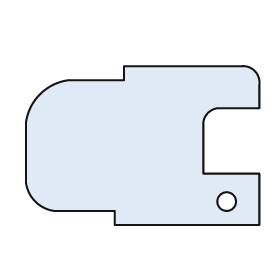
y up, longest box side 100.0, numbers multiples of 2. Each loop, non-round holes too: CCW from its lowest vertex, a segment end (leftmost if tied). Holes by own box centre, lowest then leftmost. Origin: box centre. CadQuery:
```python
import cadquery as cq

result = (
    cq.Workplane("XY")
    .moveTo(-12.0, -34.0)
    .lineTo(50.0, -34.0)
    .lineTo(50.0, -12.0)
    .lineTo(26.0, -12.0)
    .lineTo(26.0, 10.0)
    .threePointArc((28.0, 14.0), (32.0, 16.0))
    .lineTo(50.0, 16.0)
    .lineTo(50.0, 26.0)
    .threePointArc((48.0, 32.0), (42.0, 34.0))
    .lineTo(-8.0, 34.0)
    .lineTo(-8.0, 28.0)
    .lineTo(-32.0, 28.0)
    .threePointArc((-44.0, 22.0), (-50.0, 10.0))
    .lineTo(-50.0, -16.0)
    .threePointArc((-46.0, -24.0), (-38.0, -28.0))
    .lineTo(-12.0, -28.0)
    .close()
    .moveTo(36.0, -24.0)
    .circle(4.0)
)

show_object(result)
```